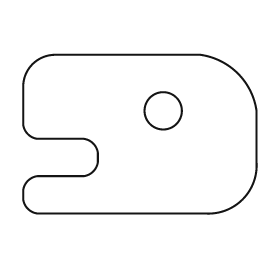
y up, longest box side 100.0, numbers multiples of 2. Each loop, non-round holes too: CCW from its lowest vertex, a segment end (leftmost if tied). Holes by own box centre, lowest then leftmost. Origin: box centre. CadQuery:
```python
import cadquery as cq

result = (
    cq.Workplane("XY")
    .moveTo(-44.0, -34.0)
    .lineTo(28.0, -34.0)
    .threePointArc((44.0, -28.0), (50.0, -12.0))
    .lineTo(50.0, 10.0)
    .threePointArc((42.0, 26.0), (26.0, 34.0))
    .lineTo(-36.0, 34.0)
    .threePointArc((-46.0, 30.0), (-50.0, 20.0))
    .lineTo(-50.0, 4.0)
    .threePointArc((-48.0, 0.0), (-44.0, -2.0))
    .lineTo(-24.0, -2.0)
    .threePointArc((-20.0, -4.0), (-18.0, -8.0))
    .lineTo(-18.0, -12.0)
    .threePointArc((-20.0, -16.0), (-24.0, -18.0))
    .lineTo(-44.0, -18.0)
    .threePointArc((-48.0, -20.0), (-50.0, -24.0))
    .lineTo(-50.0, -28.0)
    .threePointArc((-48.0, -32.0), (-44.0, -34.0))
    .close()
    .moveTo(10.0, 10.0)
    .circle(8.0)
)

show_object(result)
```